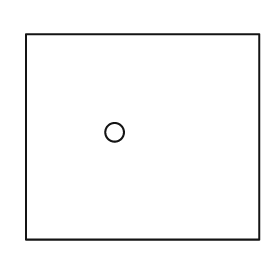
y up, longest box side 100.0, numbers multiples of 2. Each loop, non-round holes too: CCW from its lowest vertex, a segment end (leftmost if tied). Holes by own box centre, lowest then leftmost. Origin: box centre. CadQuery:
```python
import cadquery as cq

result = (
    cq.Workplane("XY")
    .moveTo(-50.0, -44.0)
    .lineTo(50.0, -44.0)
    .lineTo(50.0, 44.0)
    .lineTo(-50.0, 44.0)
    .close()
    .moveTo(-12.0, 2.0)
    .circle(4.0)
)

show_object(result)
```